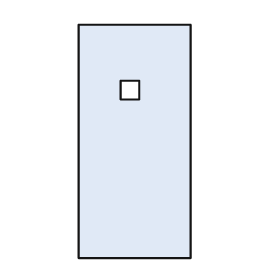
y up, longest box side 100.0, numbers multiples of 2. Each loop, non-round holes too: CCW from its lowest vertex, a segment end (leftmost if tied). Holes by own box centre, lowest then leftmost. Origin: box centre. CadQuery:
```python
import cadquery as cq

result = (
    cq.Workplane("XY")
    .moveTo(-24.0, -50.0)
    .lineTo(24.0, -50.0)
    .lineTo(24.0, 50.0)
    .lineTo(-24.0, 50.0)
    .close()
    .moveTo(-6.0, 18.0)
    .lineTo(2.0, 18.0)
    .lineTo(2.0, 26.0)
    .lineTo(-6.0, 26.0)
    .close()
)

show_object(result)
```